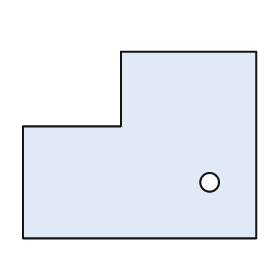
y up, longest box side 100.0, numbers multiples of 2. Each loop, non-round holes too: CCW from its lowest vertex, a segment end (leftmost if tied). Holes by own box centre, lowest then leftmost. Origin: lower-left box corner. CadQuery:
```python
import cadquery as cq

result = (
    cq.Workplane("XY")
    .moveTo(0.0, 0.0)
    .lineTo(100.0, 0.0)
    .lineTo(100.0, 80.0)
    .lineTo(42.0, 80.0)
    .lineTo(42.0, 48.0)
    .lineTo(0.0, 48.0)
    .close()
    .moveTo(80.0, 24.0)
    .circle(4.0)
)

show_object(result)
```